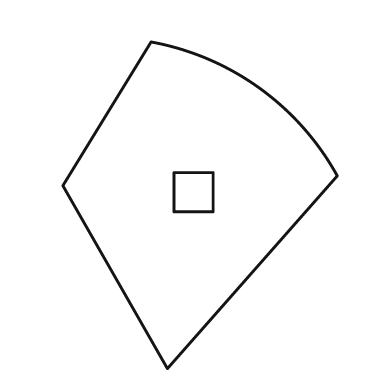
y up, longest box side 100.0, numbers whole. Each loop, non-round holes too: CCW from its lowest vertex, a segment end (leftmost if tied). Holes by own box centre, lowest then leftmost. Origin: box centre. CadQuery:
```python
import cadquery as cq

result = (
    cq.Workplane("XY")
    .moveTo(-10.0, -50.0)
    .lineTo(42.0, 9.0)
    .threePointArc((18.0, 36.0), (-15.0, 50.0))
    .lineTo(-42.0, 6.0)
    .close()
    .moveTo(-8.0, -2.0)
    .lineTo(4.0, -2.0)
    .lineTo(4.0, 10.0)
    .lineTo(-8.0, 10.0)
    .close()
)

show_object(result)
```